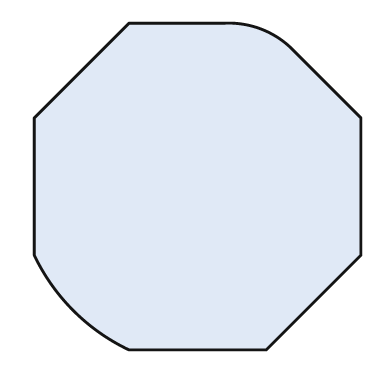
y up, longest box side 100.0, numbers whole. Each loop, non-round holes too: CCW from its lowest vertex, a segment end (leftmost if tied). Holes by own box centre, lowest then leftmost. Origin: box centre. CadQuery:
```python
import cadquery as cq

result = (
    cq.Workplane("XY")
    .moveTo(-21.0, -50.0)
    .lineTo(21.0, -50.0)
    .lineTo(50.0, -21.0)
    .lineTo(50.0, 21.0)
    .lineTo(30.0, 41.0)
    .threePointArc((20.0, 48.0), (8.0, 50.0))
    .lineTo(-21.0, 50.0)
    .lineTo(-50.0, 21.0)
    .lineTo(-50.0, -21.0)
    .threePointArc((-38.0, -38.0), (-21.0, -50.0))
    .close()
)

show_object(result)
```